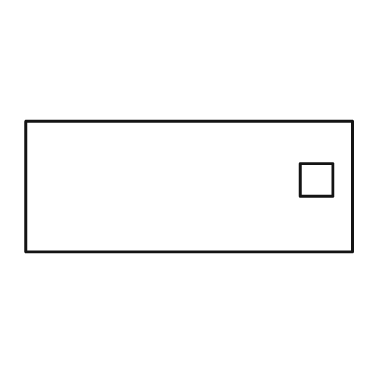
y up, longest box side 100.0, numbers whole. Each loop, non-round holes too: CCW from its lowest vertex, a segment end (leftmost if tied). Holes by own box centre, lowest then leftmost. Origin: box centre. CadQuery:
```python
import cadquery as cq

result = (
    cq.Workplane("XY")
    .moveTo(-50.0, -20.0)
    .lineTo(50.0, -20.0)
    .lineTo(50.0, 20.0)
    .lineTo(-50.0, 20.0)
    .close()
    .moveTo(34.0, -3.0)
    .lineTo(44.0, -3.0)
    .lineTo(44.0, 7.0)
    .lineTo(34.0, 7.0)
    .close()
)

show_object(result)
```